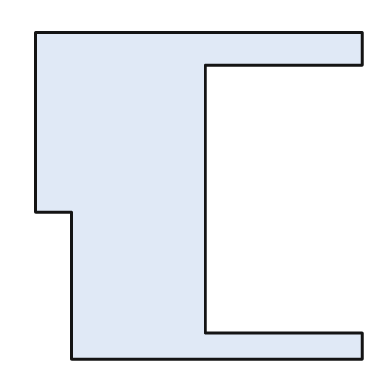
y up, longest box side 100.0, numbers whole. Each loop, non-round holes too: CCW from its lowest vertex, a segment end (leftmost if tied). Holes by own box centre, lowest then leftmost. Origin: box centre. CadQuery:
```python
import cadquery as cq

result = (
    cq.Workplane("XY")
    .moveTo(-39.0, -50.0)
    .lineTo(50.0, -50.0)
    .lineTo(50.0, -42.0)
    .lineTo(2.0, -42.0)
    .lineTo(2.0, 40.0)
    .lineTo(50.0, 40.0)
    .lineTo(50.0, 50.0)
    .lineTo(-50.0, 50.0)
    .lineTo(-50.0, -5.0)
    .lineTo(-39.0, -5.0)
    .close()
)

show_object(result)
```